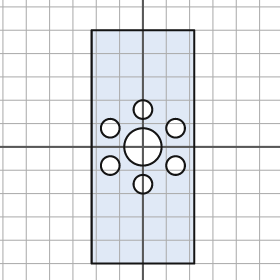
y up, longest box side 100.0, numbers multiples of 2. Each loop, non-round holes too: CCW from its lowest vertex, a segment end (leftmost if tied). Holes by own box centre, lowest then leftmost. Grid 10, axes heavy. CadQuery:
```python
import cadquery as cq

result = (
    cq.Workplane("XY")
    .moveTo(-22.0, -50.0)
    .lineTo(22.0, -50.0)
    .lineTo(22.0, 50.0)
    .lineTo(-22.0, 50.0)
    .close()
    .moveTo(0.0, -16.0)
    .circle(4.0)
    .moveTo(-14.0, -8.0)
    .circle(4.0)
    .moveTo(14.0, -8.0)
    .circle(4.0)
    .moveTo(0.0, 0.0)
    .circle(8.0)
    .moveTo(-14.0, 8.0)
    .circle(4.0)
    .moveTo(14.0, 8.0)
    .circle(4.0)
    .moveTo(0.0, 16.0)
    .circle(4.0)
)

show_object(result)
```